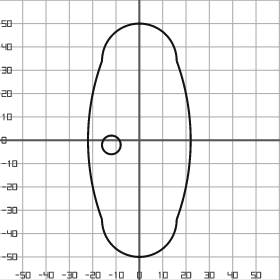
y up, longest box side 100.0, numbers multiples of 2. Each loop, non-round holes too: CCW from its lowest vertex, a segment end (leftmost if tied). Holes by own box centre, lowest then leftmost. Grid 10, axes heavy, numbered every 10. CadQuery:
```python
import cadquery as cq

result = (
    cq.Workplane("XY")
    .moveTo(-16.0, -34.0)
    .threePointArc((0.0, -50.0), (16.0, -34.0))
    .threePointArc((22.0, 0.0), (16.0, 34.0))
    .threePointArc((0.0, 50.0), (-16.0, 34.0))
    .threePointArc((-22.0, 0.0), (-16.0, -34.0))
    .close()
    .moveTo(-12.0, -2.0)
    .circle(4.0)
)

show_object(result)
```